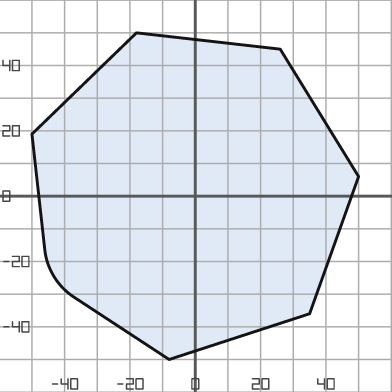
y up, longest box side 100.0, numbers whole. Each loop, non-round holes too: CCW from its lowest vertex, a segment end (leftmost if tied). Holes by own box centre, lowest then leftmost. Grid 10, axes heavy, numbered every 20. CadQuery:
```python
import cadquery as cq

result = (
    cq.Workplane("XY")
    .moveTo(-8.0, -50.0)
    .lineTo(35.0, -36.0)
    .lineTo(50.0, 6.0)
    .lineTo(26.0, 45.0)
    .lineTo(-18.0, 50.0)
    .lineTo(-50.0, 19.0)
    .lineTo(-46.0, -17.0)
    .threePointArc((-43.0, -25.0), (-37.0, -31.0))
    .close()
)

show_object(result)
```